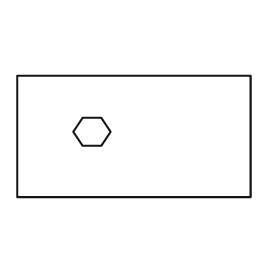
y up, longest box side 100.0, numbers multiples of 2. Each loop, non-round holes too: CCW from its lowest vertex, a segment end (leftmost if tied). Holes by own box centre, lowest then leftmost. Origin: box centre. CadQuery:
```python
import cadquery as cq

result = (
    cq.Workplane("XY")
    .moveTo(-50.0, -26.0)
    .lineTo(50.0, -26.0)
    .lineTo(50.0, 26.0)
    .lineTo(-50.0, 26.0)
    .close()
    .moveTo(-22.0, -4.0)
    .lineTo(-14.0, -4.0)
    .lineTo(-10.0, 2.0)
    .lineTo(-14.0, 8.0)
    .lineTo(-22.0, 8.0)
    .lineTo(-26.0, 2.0)
    .close()
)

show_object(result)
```